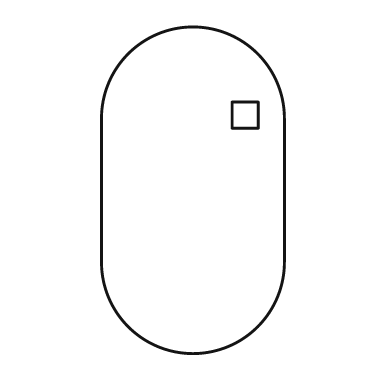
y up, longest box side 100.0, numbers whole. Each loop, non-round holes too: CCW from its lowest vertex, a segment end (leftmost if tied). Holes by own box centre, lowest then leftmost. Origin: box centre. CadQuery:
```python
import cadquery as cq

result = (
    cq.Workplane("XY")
    .moveTo(-28.0, -22.0)
    .threePointArc((0.0, -50.0), (28.0, -22.0))
    .lineTo(28.0, 22.0)
    .threePointArc((0.0, 50.0), (-28.0, 22.0))
    .close()
    .moveTo(12.0, 19.0)
    .lineTo(20.0, 19.0)
    .lineTo(20.0, 27.0)
    .lineTo(12.0, 27.0)
    .close()
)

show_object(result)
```